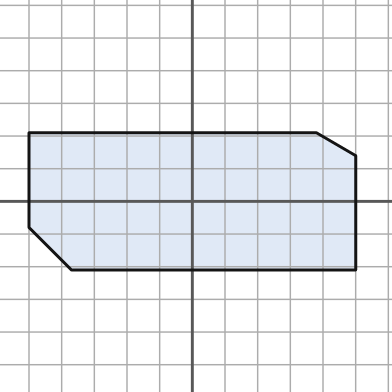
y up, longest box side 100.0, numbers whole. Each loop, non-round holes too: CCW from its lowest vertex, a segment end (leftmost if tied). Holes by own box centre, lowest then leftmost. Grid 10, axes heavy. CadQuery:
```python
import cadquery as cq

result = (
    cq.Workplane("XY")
    .moveTo(-37.0, -21.0)
    .lineTo(50.0, -21.0)
    .lineTo(50.0, 14.0)
    .lineTo(38.0, 21.0)
    .lineTo(-50.0, 21.0)
    .lineTo(-50.0, -8.0)
    .close()
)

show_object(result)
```